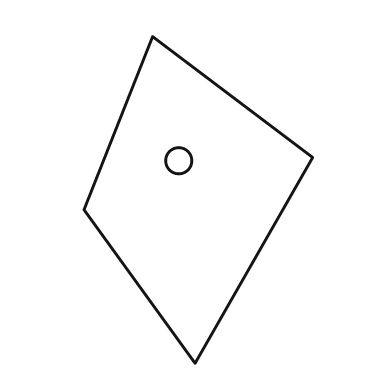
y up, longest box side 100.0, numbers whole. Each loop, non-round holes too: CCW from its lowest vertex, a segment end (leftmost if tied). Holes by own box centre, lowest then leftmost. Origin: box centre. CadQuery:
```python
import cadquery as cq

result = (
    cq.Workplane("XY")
    .moveTo(-1.0, -50.0)
    .lineTo(35.0, 13.0)
    .lineTo(-14.0, 50.0)
    .lineTo(-35.0, -3.0)
    .close()
    .moveTo(-6.0, 12.0)
    .circle(4.0)
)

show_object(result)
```